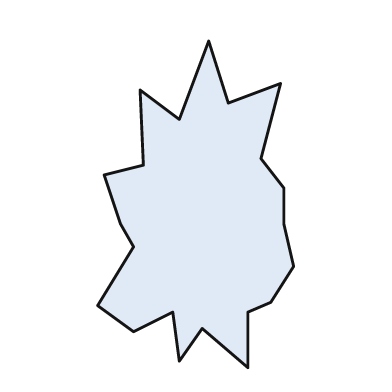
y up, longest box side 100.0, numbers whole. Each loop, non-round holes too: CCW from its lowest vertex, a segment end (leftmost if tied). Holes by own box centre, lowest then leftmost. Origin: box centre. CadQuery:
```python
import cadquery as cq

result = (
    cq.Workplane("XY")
    .moveTo(16.0, -50.0)
    .lineTo(16.0, -33.0)
    .lineTo(23.0, -30.0)
    .lineTo(30.0, -19.0)
    .lineTo(27.0, -6.0)
    .lineTo(27.0, 5.0)
    .lineTo(20.0, 14.0)
    .lineTo(26.0, 37.0)
    .lineTo(10.0, 31.0)
    .lineTo(4.0, 50.0)
    .lineTo(-5.0, 26.0)
    .lineTo(-17.0, 35.0)
    .lineTo(-16.0, 12.0)
    .lineTo(-28.0, 9.0)
    .lineTo(-23.0, -6.0)
    .lineTo(-19.0, -13.0)
    .lineTo(-30.0, -31.0)
    .lineTo(-19.0, -39.0)
    .lineTo(-7.0, -33.0)
    .lineTo(-5.0, -48.0)
    .lineTo(2.0, -38.0)
    .close()
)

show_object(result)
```